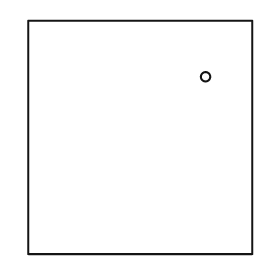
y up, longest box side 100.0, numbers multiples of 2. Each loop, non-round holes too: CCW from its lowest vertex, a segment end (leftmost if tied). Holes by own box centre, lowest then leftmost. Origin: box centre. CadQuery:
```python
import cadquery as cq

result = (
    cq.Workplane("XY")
    .moveTo(-48.0, -50.0)
    .lineTo(48.0, -50.0)
    .lineTo(48.0, 50.0)
    .lineTo(-48.0, 50.0)
    .close()
    .moveTo(28.0, 26.0)
    .circle(2.0)
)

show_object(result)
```